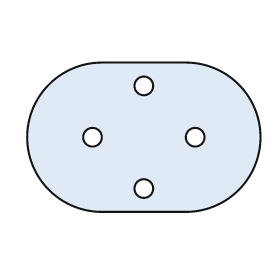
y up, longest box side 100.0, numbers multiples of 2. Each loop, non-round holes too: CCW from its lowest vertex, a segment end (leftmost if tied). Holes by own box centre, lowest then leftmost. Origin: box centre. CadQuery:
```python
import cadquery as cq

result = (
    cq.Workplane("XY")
    .moveTo(-18.0, -32.0)
    .lineTo(18.0, -32.0)
    .threePointArc((50.0, 0.0), (18.0, 32.0))
    .lineTo(-18.0, 32.0)
    .threePointArc((-50.0, 0.0), (-18.0, -32.0))
    .close()
    .moveTo(0.0, -22.0)
    .circle(4.0)
    .moveTo(-22.0, 0.0)
    .circle(4.0)
    .moveTo(22.0, 0.0)
    .circle(4.0)
    .moveTo(0.0, 22.0)
    .circle(4.0)
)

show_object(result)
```